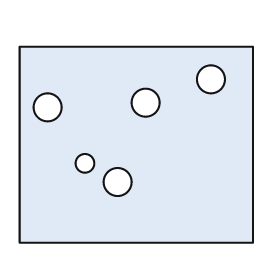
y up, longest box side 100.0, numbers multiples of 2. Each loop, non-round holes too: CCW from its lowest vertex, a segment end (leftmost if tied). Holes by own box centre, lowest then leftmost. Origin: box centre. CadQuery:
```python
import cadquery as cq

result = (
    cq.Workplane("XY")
    .moveTo(-50.0, -42.0)
    .lineTo(50.0, -42.0)
    .lineTo(50.0, 42.0)
    .lineTo(-50.0, 42.0)
    .close()
    .moveTo(-8.0, -16.0)
    .circle(6.0)
    .moveTo(-22.0, -8.0)
    .circle(4.0)
    .moveTo(-38.0, 16.0)
    .circle(6.0)
    .moveTo(4.0, 18.0)
    .circle(6.0)
    .moveTo(32.0, 28.0)
    .circle(6.0)
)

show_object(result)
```